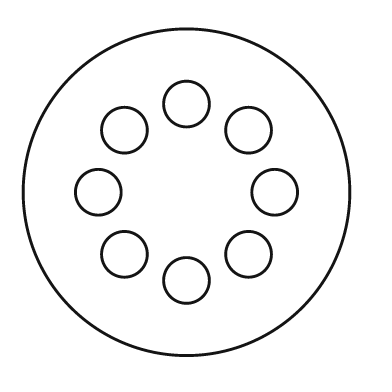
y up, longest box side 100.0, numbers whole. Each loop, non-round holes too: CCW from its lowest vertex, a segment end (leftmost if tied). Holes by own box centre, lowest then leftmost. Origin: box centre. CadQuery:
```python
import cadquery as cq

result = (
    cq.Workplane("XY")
    .moveTo(0.0, 0.0)
    .circle(50.0)
    .moveTo(0.0, -27.0)
    .circle(7.0)
    .moveTo(-19.0, -19.0)
    .circle(7.0)
    .moveTo(19.0, -19.0)
    .circle(7.0)
    .moveTo(-27.0, 0.0)
    .circle(7.0)
    .moveTo(27.0, 0.0)
    .circle(7.0)
    .moveTo(-19.0, 19.0)
    .circle(7.0)
    .moveTo(19.0, 19.0)
    .circle(7.0)
    .moveTo(0.0, 27.0)
    .circle(7.0)
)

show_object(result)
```